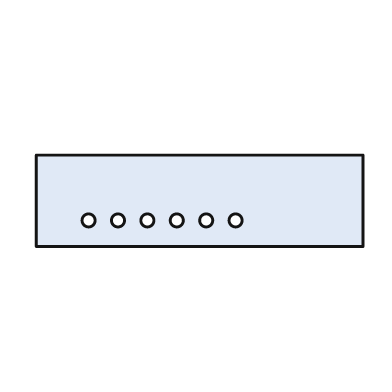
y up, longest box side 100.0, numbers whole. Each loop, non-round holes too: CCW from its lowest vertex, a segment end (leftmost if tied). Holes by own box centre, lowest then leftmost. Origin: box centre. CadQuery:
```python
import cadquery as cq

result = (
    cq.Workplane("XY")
    .moveTo(-50.0, -14.0)
    .lineTo(50.0, -14.0)
    .lineTo(50.0, 14.0)
    .lineTo(-50.0, 14.0)
    .close()
    .moveTo(-34.0, -6.0)
    .circle(2.0)
    .moveTo(-25.0, -6.0)
    .circle(2.0)
    .moveTo(-16.0, -6.0)
    .circle(2.0)
    .moveTo(-7.0, -6.0)
    .circle(2.0)
    .moveTo(2.0, -6.0)
    .circle(2.0)
    .moveTo(11.0, -6.0)
    .circle(2.0)
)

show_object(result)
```